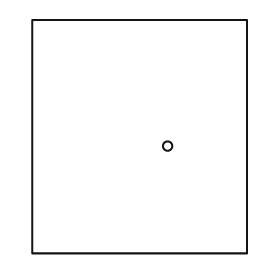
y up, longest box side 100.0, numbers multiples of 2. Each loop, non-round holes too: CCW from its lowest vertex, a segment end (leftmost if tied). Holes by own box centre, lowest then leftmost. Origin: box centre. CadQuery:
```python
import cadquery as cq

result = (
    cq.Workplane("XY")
    .moveTo(-46.0, -50.0)
    .lineTo(46.0, -50.0)
    .lineTo(46.0, 50.0)
    .lineTo(-46.0, 50.0)
    .close()
    .moveTo(12.0, -4.0)
    .circle(2.0)
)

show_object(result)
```